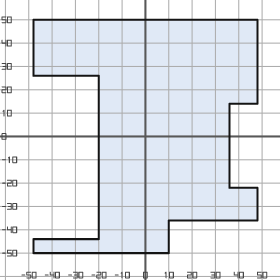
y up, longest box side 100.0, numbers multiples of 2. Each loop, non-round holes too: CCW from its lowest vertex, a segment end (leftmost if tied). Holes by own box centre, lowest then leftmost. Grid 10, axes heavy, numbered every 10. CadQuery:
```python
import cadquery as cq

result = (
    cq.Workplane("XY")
    .moveTo(-48.0, -50.0)
    .lineTo(10.0, -50.0)
    .lineTo(10.0, -36.0)
    .lineTo(48.0, -36.0)
    .lineTo(48.0, -22.0)
    .lineTo(36.0, -22.0)
    .lineTo(36.0, 14.0)
    .lineTo(48.0, 14.0)
    .lineTo(48.0, 50.0)
    .lineTo(-48.0, 50.0)
    .lineTo(-48.0, 26.0)
    .lineTo(-20.0, 26.0)
    .lineTo(-20.0, -44.0)
    .lineTo(-48.0, -44.0)
    .close()
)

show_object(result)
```